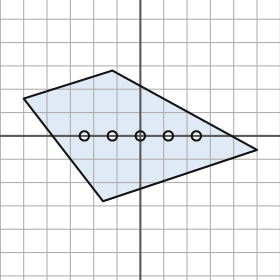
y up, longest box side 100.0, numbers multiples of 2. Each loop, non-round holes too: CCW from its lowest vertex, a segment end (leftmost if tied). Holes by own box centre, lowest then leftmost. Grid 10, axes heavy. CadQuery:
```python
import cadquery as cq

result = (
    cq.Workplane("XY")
    .moveTo(-16.0, -28.0)
    .lineTo(50.0, -6.0)
    .lineTo(-12.0, 28.0)
    .lineTo(-50.0, 16.0)
    .close()
    .moveTo(-24.0, 0.0)
    .circle(2.0)
    .moveTo(-12.0, 0.0)
    .circle(2.0)
    .moveTo(0.0, 0.0)
    .circle(2.0)
    .moveTo(12.0, 0.0)
    .circle(2.0)
    .moveTo(24.0, 0.0)
    .circle(2.0)
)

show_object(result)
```